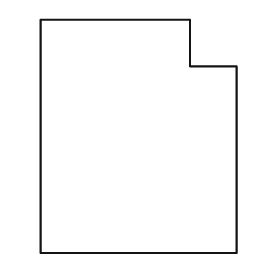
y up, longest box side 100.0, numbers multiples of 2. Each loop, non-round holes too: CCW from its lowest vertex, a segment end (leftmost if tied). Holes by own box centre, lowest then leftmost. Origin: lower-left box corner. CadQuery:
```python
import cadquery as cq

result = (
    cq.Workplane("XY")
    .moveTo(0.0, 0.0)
    .lineTo(84.0, 0.0)
    .lineTo(84.0, 80.0)
    .lineTo(64.0, 80.0)
    .lineTo(64.0, 100.0)
    .lineTo(0.0, 100.0)
    .close()
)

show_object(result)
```